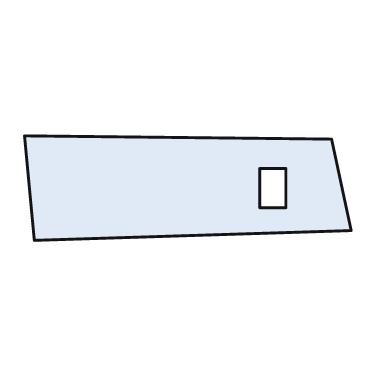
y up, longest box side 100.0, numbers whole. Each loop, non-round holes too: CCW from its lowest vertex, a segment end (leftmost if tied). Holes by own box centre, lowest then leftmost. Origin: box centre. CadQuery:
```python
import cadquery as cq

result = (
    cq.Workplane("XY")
    .moveTo(-47.0, -16.0)
    .lineTo(50.0, -13.0)
    .lineTo(44.0, 15.0)
    .lineTo(-50.0, 16.0)
    .close()
    .moveTo(22.0, -6.0)
    .lineTo(30.0, -6.0)
    .lineTo(30.0, 6.0)
    .lineTo(22.0, 6.0)
    .close()
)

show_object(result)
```